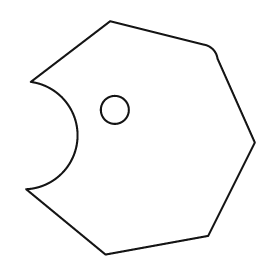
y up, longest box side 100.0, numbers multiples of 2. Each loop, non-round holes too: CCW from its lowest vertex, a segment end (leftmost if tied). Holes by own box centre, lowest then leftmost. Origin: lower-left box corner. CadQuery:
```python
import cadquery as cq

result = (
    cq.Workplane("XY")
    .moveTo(34.0, 0.0)
    .lineTo(78.0, 8.0)
    .lineTo(98.0, 48.0)
    .lineTo(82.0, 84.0)
    .threePointArc((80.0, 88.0), (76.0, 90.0))
    .lineTo(36.0, 100.0)
    .lineTo(2.0, 74.0)
    .threePointArc((22.0, 50.0), (0.0, 28.0))
    .close()
    .moveTo(38.0, 62.0)
    .circle(6.0)
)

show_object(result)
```